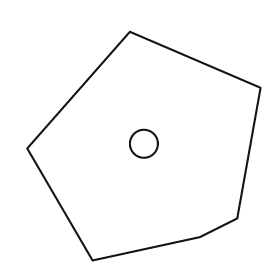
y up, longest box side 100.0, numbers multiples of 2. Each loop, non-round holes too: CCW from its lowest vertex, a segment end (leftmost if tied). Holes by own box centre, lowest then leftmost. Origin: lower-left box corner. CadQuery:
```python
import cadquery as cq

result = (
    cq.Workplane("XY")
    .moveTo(28.0, 0.0)
    .lineTo(74.0, 10.0)
    .lineTo(90.0, 18.0)
    .lineTo(100.0, 74.0)
    .lineTo(44.0, 98.0)
    .lineTo(0.0, 48.0)
    .close()
    .moveTo(50.0, 50.0)
    .circle(6.0)
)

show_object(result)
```